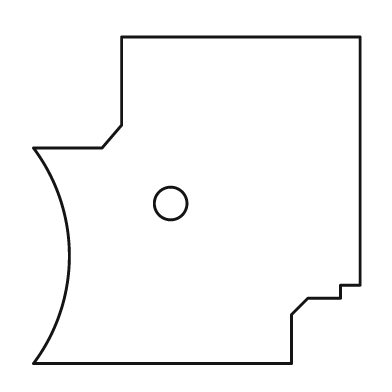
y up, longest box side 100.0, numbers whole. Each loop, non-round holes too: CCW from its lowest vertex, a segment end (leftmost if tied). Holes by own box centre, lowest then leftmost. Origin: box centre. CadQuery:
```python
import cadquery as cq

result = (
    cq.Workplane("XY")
    .moveTo(-50.0, -50.0)
    .lineTo(29.0, -50.0)
    .lineTo(29.0, -35.0)
    .lineTo(34.0, -30.0)
    .lineTo(44.0, -30.0)
    .lineTo(44.0, -26.0)
    .lineTo(50.0, -26.0)
    .lineTo(50.0, 50.0)
    .lineTo(-23.0, 50.0)
    .lineTo(-23.0, 23.0)
    .lineTo(-29.0, 16.0)
    .lineTo(-50.0, 16.0)
    .threePointArc((-39.0, -17.0), (-50.0, -50.0))
    .close()
    .moveTo(-8.0, -1.0)
    .circle(5.0)
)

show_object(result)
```